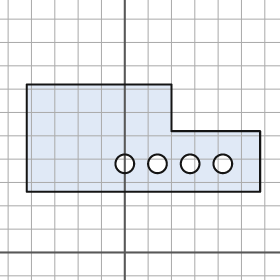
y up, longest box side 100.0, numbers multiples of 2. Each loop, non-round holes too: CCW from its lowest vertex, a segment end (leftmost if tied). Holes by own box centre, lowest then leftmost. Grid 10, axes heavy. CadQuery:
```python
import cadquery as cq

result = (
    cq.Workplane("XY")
    .moveTo(-42.0, 26.0)
    .lineTo(58.0, 26.0)
    .lineTo(58.0, 52.0)
    .lineTo(20.0, 52.0)
    .lineTo(20.0, 72.0)
    .lineTo(-42.0, 72.0)
    .close()
    .moveTo(0.0, 38.0)
    .circle(4.0)
    .moveTo(14.0, 38.0)
    .circle(4.0)
    .moveTo(28.0, 38.0)
    .circle(4.0)
    .moveTo(42.0, 38.0)
    .circle(4.0)
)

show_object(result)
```